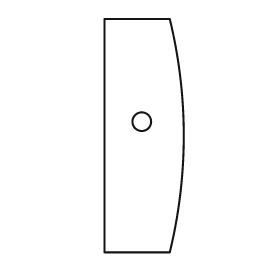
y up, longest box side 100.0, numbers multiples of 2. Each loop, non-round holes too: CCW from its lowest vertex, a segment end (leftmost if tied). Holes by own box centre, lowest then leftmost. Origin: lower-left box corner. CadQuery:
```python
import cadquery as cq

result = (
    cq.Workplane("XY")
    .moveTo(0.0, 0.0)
    .lineTo(28.0, 0.0)
    .threePointArc((34.0, 50.0), (28.0, 100.0))
    .lineTo(0.0, 100.0)
    .close()
    .moveTo(16.0, 56.0)
    .circle(4.0)
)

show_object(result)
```